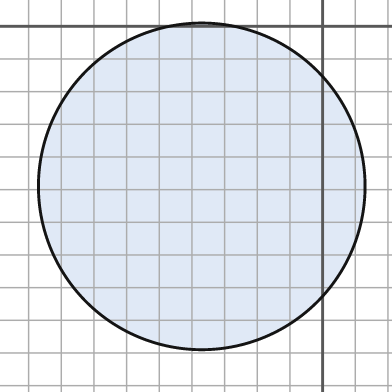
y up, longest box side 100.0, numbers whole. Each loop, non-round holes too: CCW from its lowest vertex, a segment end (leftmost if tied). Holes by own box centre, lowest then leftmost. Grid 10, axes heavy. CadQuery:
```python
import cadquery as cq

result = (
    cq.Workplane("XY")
    .moveTo(-37.0, -49.0)
    .circle(50.0)
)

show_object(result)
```